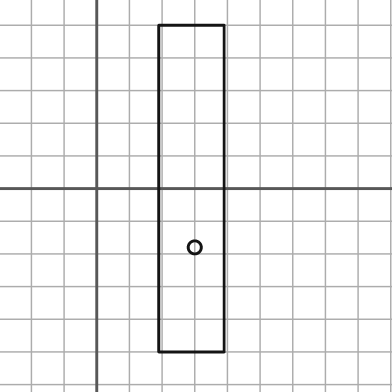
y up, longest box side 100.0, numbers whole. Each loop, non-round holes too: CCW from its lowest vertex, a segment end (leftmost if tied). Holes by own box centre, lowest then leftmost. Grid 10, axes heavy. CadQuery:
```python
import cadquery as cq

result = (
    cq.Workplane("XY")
    .moveTo(19.0, -50.0)
    .lineTo(39.0, -50.0)
    .lineTo(39.0, 50.0)
    .lineTo(19.0, 50.0)
    .close()
    .moveTo(30.0, -18.0)
    .circle(2.0)
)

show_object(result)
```